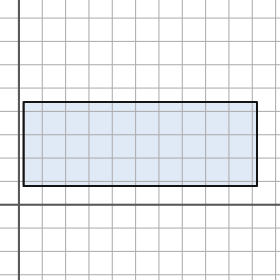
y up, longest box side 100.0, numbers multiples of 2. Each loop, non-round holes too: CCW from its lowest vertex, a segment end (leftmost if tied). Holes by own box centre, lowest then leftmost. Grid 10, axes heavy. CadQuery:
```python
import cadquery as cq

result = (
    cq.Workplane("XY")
    .moveTo(2.0, 8.0)
    .lineTo(102.0, 8.0)
    .lineTo(102.0, 44.0)
    .lineTo(2.0, 44.0)
    .close()
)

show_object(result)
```